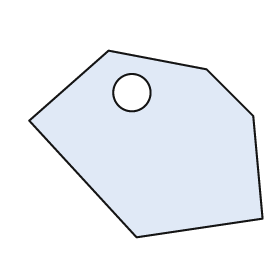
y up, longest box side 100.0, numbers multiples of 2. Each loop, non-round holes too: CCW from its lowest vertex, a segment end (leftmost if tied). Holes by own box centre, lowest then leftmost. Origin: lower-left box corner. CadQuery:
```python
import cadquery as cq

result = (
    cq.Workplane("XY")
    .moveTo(46.0, 0.0)
    .lineTo(100.0, 8.0)
    .lineTo(96.0, 52.0)
    .lineTo(76.0, 72.0)
    .lineTo(34.0, 80.0)
    .lineTo(0.0, 50.0)
    .close()
    .moveTo(44.0, 62.0)
    .circle(8.0)
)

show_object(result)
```